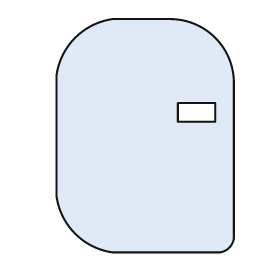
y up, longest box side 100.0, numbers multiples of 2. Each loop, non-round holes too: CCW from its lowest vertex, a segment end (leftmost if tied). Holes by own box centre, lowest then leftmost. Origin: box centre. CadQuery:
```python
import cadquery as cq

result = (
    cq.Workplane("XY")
    .moveTo(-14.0, -50.0)
    .lineTo(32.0, -50.0)
    .threePointArc((36.0, -48.0), (38.0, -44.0))
    .lineTo(38.0, 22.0)
    .threePointArc((30.0, 42.0), (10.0, 50.0))
    .lineTo(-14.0, 50.0)
    .threePointArc((-30.0, 42.0), (-38.0, 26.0))
    .lineTo(-38.0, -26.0)
    .threePointArc((-30.0, -42.0), (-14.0, -50.0))
    .close()
    .moveTo(14.0, 6.0)
    .lineTo(30.0, 6.0)
    .lineTo(30.0, 14.0)
    .lineTo(14.0, 14.0)
    .close()
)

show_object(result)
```